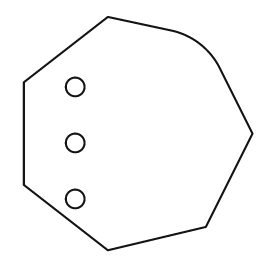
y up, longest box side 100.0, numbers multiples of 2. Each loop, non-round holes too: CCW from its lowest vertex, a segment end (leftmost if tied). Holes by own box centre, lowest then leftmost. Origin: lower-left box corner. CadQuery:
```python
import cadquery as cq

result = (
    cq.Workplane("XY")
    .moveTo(36.0, 0.0)
    .lineTo(78.0, 10.0)
    .lineTo(98.0, 50.0)
    .lineTo(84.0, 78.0)
    .threePointArc((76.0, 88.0), (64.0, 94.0))
    .lineTo(36.0, 100.0)
    .lineTo(0.0, 72.0)
    .lineTo(0.0, 28.0)
    .close()
    .moveTo(22.0, 22.0)
    .circle(4.0)
    .moveTo(22.0, 46.0)
    .circle(4.0)
    .moveTo(22.0, 70.0)
    .circle(4.0)
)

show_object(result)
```